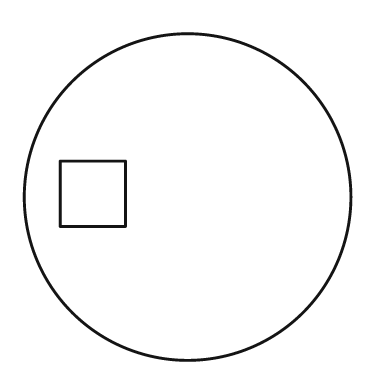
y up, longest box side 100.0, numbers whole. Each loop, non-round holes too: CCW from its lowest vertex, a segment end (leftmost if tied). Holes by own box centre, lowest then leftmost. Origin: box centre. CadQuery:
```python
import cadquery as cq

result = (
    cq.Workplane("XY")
    .moveTo(0.0, 0.0)
    .circle(50.0)
    .moveTo(-39.0, -9.0)
    .lineTo(-19.0, -9.0)
    .lineTo(-19.0, 11.0)
    .lineTo(-39.0, 11.0)
    .close()
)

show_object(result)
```